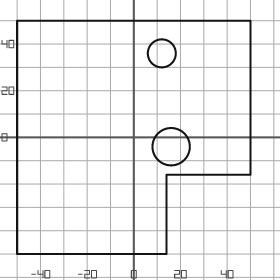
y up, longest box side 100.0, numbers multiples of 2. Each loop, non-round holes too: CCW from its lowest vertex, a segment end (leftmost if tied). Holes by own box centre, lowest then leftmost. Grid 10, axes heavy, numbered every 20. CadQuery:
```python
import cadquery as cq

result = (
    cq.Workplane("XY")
    .moveTo(-50.0, -50.0)
    .lineTo(14.0, -50.0)
    .lineTo(14.0, -16.0)
    .lineTo(50.0, -16.0)
    .lineTo(50.0, 50.0)
    .lineTo(-50.0, 50.0)
    .close()
    .moveTo(16.0, -4.0)
    .circle(8.0)
    .moveTo(12.0, 36.0)
    .circle(6.0)
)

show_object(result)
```